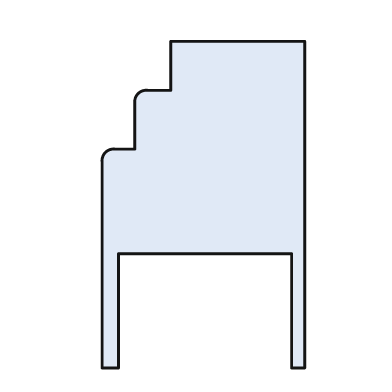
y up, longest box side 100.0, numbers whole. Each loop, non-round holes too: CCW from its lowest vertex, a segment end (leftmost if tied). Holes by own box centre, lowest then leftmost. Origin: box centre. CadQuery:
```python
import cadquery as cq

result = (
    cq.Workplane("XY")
    .moveTo(-31.0, -50.0)
    .lineTo(-26.0, -50.0)
    .lineTo(-26.0, -15.0)
    .lineTo(27.0, -15.0)
    .lineTo(27.0, -50.0)
    .lineTo(31.0, -50.0)
    .lineTo(31.0, 50.0)
    .lineTo(-10.0, 50.0)
    .lineTo(-10.0, 35.0)
    .lineTo(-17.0, 35.0)
    .threePointArc((-20.0, 34.0), (-21.0, 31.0))
    .lineTo(-21.0, 17.0)
    .lineTo(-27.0, 17.0)
    .threePointArc((-30.0, 16.0), (-31.0, 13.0))
    .close()
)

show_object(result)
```